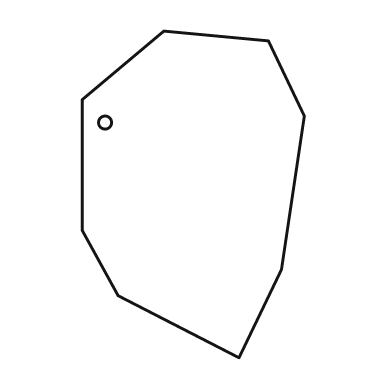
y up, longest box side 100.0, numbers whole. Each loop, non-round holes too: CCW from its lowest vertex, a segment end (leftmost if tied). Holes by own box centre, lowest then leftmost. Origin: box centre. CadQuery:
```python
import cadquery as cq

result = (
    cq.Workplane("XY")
    .moveTo(14.0, -50.0)
    .lineTo(27.0, -23.0)
    .lineTo(34.0, 24.0)
    .lineTo(23.0, 47.0)
    .lineTo(-9.0, 50.0)
    .lineTo(-34.0, 29.0)
    .lineTo(-34.0, -11.0)
    .lineTo(-23.0, -31.0)
    .close()
    .moveTo(-27.0, 22.0)
    .circle(2.0)
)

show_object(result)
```